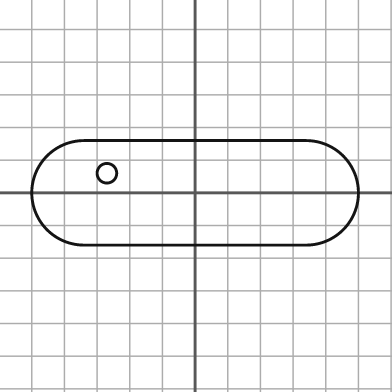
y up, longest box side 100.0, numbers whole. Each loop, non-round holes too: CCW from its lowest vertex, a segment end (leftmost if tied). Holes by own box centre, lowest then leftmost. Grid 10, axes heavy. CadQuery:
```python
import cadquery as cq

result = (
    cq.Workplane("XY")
    .moveTo(-34.0, -16.0)
    .lineTo(34.0, -16.0)
    .threePointArc((50.0, 0.0), (34.0, 16.0))
    .lineTo(-34.0, 16.0)
    .threePointArc((-50.0, 0.0), (-34.0, -16.0))
    .close()
    .moveTo(-27.0, 6.0)
    .circle(3.0)
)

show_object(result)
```